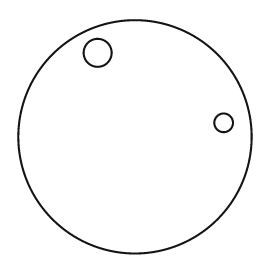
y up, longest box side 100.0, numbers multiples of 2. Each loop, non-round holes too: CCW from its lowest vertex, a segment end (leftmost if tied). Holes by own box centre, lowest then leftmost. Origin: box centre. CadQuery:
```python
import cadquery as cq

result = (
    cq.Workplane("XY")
    .moveTo(0.0, 0.0)
    .circle(50.0)
    .moveTo(38.0, 6.0)
    .circle(4.0)
    .moveTo(-16.0, 36.0)
    .circle(6.0)
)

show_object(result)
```